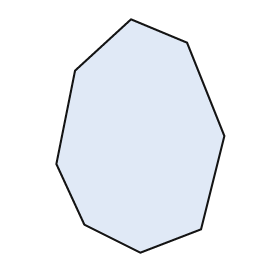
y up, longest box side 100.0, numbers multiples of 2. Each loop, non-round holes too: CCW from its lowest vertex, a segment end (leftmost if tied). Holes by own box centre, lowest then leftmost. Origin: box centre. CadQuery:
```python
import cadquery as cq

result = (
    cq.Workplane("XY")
    .moveTo(0.0, -50.0)
    .lineTo(26.0, -40.0)
    .lineTo(36.0, 0.0)
    .lineTo(20.0, 40.0)
    .lineTo(-4.0, 50.0)
    .lineTo(-28.0, 28.0)
    .lineTo(-36.0, -12.0)
    .lineTo(-24.0, -38.0)
    .close()
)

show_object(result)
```